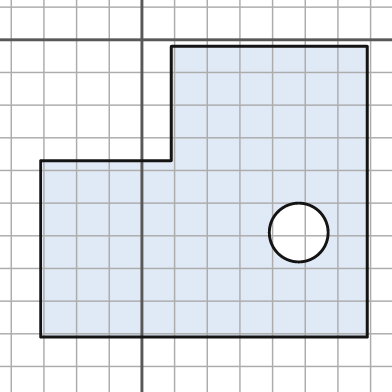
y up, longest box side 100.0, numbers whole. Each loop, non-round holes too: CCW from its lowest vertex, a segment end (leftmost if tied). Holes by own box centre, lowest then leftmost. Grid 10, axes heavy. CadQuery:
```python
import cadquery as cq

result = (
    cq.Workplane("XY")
    .moveTo(-31.0, -91.0)
    .lineTo(69.0, -91.0)
    .lineTo(69.0, -2.0)
    .lineTo(9.0, -2.0)
    .lineTo(9.0, -37.0)
    .lineTo(-31.0, -37.0)
    .close()
    .moveTo(48.0, -59.0)
    .circle(9.0)
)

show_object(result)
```